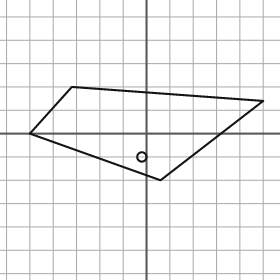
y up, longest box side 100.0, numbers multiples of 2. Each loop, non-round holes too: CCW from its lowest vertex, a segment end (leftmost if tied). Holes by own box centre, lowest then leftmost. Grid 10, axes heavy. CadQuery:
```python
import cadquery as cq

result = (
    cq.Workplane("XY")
    .moveTo(6.0, -20.0)
    .lineTo(50.0, 14.0)
    .lineTo(-32.0, 20.0)
    .lineTo(-50.0, 0.0)
    .close()
    .moveTo(-2.0, -10.0)
    .circle(2.0)
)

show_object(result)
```